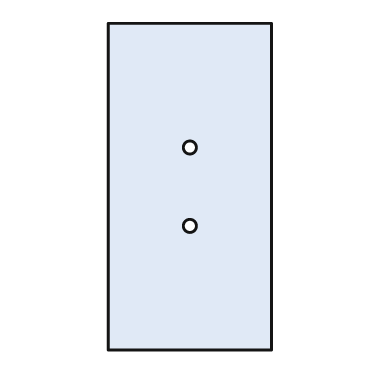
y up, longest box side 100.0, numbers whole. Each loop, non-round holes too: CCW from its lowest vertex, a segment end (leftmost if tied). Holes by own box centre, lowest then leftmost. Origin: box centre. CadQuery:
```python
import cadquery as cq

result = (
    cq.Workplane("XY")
    .moveTo(-25.0, -50.0)
    .lineTo(25.0, -50.0)
    .lineTo(25.0, 50.0)
    .lineTo(-25.0, 50.0)
    .close()
    .moveTo(0.0, -12.0)
    .circle(2.0)
    .moveTo(0.0, 12.0)
    .circle(2.0)
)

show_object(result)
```